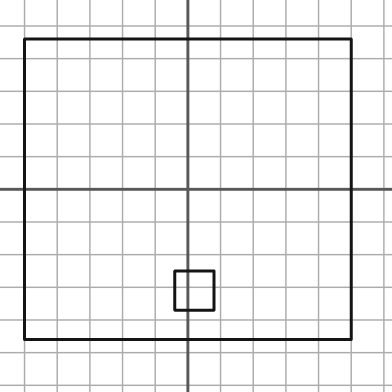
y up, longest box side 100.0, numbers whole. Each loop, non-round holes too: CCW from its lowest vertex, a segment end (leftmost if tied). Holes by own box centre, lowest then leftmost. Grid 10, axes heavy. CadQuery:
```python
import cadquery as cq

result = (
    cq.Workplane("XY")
    .moveTo(-50.0, -46.0)
    .lineTo(50.0, -46.0)
    .lineTo(50.0, 46.0)
    .lineTo(-50.0, 46.0)
    .close()
    .moveTo(-4.0, -37.0)
    .lineTo(8.0, -37.0)
    .lineTo(8.0, -25.0)
    .lineTo(-4.0, -25.0)
    .close()
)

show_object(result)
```